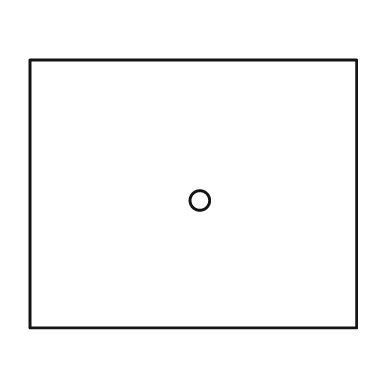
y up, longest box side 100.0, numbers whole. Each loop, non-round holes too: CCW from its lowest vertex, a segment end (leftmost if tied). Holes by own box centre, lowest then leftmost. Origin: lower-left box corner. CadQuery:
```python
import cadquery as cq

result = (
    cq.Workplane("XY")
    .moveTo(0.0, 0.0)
    .lineTo(100.0, 0.0)
    .lineTo(100.0, 82.0)
    .lineTo(0.0, 82.0)
    .close()
    .moveTo(52.0, 39.0)
    .circle(3.0)
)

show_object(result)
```